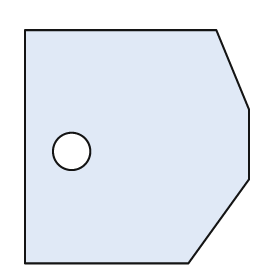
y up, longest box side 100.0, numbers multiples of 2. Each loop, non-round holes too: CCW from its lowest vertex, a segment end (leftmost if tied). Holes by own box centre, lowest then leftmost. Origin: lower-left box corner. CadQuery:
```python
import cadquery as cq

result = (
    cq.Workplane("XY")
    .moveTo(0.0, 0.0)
    .lineTo(70.0, 0.0)
    .lineTo(96.0, 36.0)
    .lineTo(96.0, 66.0)
    .lineTo(82.0, 100.0)
    .lineTo(0.0, 100.0)
    .close()
    .moveTo(20.0, 48.0)
    .circle(8.0)
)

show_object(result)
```